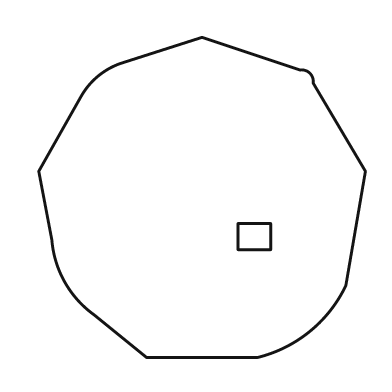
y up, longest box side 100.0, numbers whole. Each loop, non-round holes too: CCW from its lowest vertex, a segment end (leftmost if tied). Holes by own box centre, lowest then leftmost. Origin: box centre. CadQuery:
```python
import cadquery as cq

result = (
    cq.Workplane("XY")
    .moveTo(-17.0, -49.0)
    .lineTo(17.0, -49.0)
    .threePointArc((33.0, -41.0), (44.0, -27.0))
    .lineTo(50.0, 8.0)
    .lineTo(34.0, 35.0)
    .threePointArc((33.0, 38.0), (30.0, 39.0))
    .lineTo(0.0, 49.0)
    .lineTo(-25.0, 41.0)
    .threePointArc((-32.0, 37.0), (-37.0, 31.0))
    .lineTo(-50.0, 8.0)
    .lineTo(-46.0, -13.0)
    .threePointArc((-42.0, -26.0), (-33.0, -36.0))
    .close()
    .moveTo(11.0, -16.0)
    .lineTo(21.0, -16.0)
    .lineTo(21.0, -8.0)
    .lineTo(11.0, -8.0)
    .close()
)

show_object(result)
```